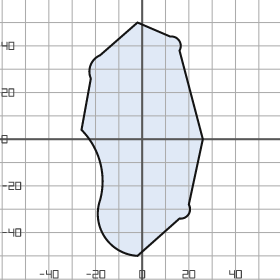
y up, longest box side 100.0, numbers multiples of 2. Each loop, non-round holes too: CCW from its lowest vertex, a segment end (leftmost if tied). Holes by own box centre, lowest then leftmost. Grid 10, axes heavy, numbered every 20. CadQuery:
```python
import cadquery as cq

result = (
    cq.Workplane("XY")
    .moveTo(-2.0, -50.0)
    .lineTo(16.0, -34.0)
    .threePointArc((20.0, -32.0), (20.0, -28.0))
    .lineTo(26.0, 0.0)
    .lineTo(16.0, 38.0)
    .threePointArc((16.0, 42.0), (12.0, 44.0))
    .lineTo(-2.0, 50.0)
    .lineTo(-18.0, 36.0)
    .threePointArc((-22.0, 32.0), (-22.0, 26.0))
    .lineTo(-26.0, 4.0)
    .threePointArc((-18.0, -10.0), (-18.0, -26.0))
    .threePointArc((-16.0, -42.0), (-2.0, -50.0))
    .close()
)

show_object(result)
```